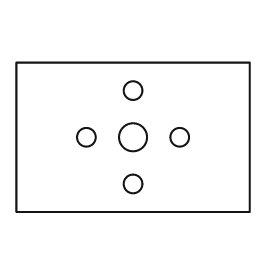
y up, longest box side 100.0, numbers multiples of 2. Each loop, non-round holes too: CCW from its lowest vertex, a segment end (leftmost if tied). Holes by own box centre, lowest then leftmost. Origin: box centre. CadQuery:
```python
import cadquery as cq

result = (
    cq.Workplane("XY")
    .moveTo(-50.0, -32.0)
    .lineTo(50.0, -32.0)
    .lineTo(50.0, 32.0)
    .lineTo(-50.0, 32.0)
    .close()
    .moveTo(0.0, -20.0)
    .circle(4.0)
    .moveTo(-20.0, 0.0)
    .circle(4.0)
    .moveTo(0.0, 0.0)
    .circle(6.0)
    .moveTo(20.0, 0.0)
    .circle(4.0)
    .moveTo(0.0, 20.0)
    .circle(4.0)
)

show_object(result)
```